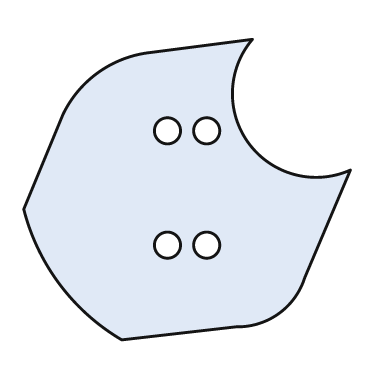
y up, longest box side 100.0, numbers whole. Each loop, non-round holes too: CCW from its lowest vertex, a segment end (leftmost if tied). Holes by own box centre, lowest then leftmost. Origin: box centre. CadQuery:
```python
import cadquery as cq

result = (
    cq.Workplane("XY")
    .moveTo(-20.0, -46.0)
    .lineTo(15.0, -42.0)
    .threePointArc((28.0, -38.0), (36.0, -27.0))
    .lineTo(50.0, 6.0)
    .threePointArc((19.0, 14.0), (20.0, 46.0))
    .lineTo(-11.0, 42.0)
    .threePointArc((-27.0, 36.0), (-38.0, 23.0))
    .lineTo(-50.0, -6.0)
    .threePointArc((-39.0, -29.0), (-20.0, -46.0))
    .close()
    .moveTo(-6.0, -17.0)
    .circle(4.0)
    .moveTo(6.0, -17.0)
    .circle(4.0)
    .moveTo(-6.0, 18.0)
    .circle(4.0)
    .moveTo(6.0, 18.0)
    .circle(4.0)
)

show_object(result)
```